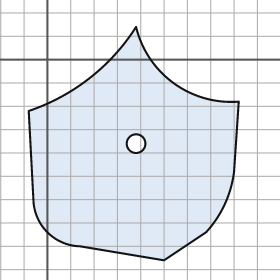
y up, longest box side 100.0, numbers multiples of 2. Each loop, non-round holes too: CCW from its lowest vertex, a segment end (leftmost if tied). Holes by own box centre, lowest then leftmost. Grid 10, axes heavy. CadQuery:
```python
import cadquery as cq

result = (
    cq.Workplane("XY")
    .moveTo(50.0, -86.0)
    .lineTo(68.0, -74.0)
    .threePointArc((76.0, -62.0), (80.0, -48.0))
    .lineTo(82.0, -18.0)
    .threePointArc((54.0, -10.0), (38.0, 14.0))
    .threePointArc((18.0, -8.0), (-8.0, -22.0))
    .lineTo(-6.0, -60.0)
    .threePointArc((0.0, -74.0), (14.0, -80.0))
    .close()
    .moveTo(38.0, -36.0)
    .circle(4.0)
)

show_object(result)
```